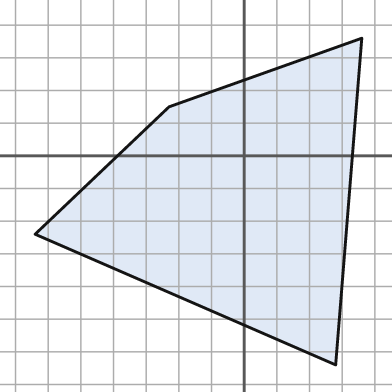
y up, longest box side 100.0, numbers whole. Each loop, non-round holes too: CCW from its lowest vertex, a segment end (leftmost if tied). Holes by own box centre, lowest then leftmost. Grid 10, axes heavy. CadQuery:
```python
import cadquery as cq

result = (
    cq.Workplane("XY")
    .moveTo(28.0, -64.0)
    .lineTo(36.0, 36.0)
    .lineTo(-23.0, 15.0)
    .lineTo(-64.0, -24.0)
    .close()
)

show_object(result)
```